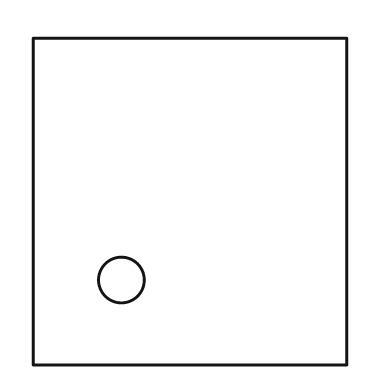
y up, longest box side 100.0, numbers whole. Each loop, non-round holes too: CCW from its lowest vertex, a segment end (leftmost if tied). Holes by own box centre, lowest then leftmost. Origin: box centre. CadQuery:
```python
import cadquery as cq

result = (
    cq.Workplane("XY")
    .moveTo(-48.0, -50.0)
    .lineTo(48.0, -50.0)
    .lineTo(48.0, 50.0)
    .lineTo(-48.0, 50.0)
    .close()
    .moveTo(-21.0, -24.0)
    .circle(7.0)
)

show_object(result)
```